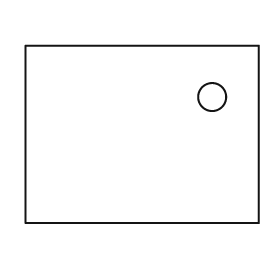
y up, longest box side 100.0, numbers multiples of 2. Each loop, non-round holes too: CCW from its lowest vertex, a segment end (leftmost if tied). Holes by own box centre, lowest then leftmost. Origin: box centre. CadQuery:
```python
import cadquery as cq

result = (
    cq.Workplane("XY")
    .moveTo(-50.0, -38.0)
    .lineTo(50.0, -38.0)
    .lineTo(50.0, 38.0)
    .lineTo(-50.0, 38.0)
    .close()
    .moveTo(30.0, 16.0)
    .circle(6.0)
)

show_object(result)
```